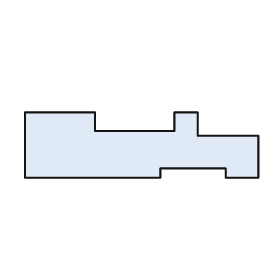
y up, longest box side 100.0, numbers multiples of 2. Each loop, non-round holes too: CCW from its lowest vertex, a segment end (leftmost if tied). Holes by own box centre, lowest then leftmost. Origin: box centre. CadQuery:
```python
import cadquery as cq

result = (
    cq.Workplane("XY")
    .moveTo(-50.0, -14.0)
    .lineTo(8.0, -14.0)
    .lineTo(8.0, -10.0)
    .lineTo(36.0, -10.0)
    .lineTo(36.0, -14.0)
    .lineTo(50.0, -14.0)
    .lineTo(50.0, 4.0)
    .lineTo(24.0, 4.0)
    .lineTo(24.0, 14.0)
    .lineTo(14.0, 14.0)
    .lineTo(14.0, 6.0)
    .lineTo(-20.0, 6.0)
    .lineTo(-20.0, 14.0)
    .lineTo(-50.0, 14.0)
    .close()
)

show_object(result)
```